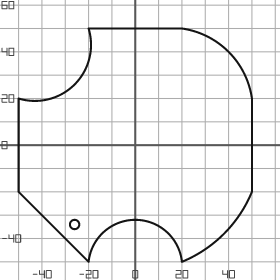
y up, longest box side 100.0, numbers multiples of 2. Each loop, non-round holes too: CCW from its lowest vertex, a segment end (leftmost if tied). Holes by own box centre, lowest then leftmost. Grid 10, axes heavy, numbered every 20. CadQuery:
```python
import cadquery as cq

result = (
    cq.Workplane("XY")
    .moveTo(-20.0, -50.0)
    .threePointArc((0.0, -32.0), (20.0, -50.0))
    .threePointArc((38.0, -38.0), (50.0, -20.0))
    .lineTo(50.0, 20.0)
    .threePointArc((40.0, 40.0), (20.0, 50.0))
    .lineTo(-20.0, 50.0)
    .threePointArc((-26.0, 26.0), (-50.0, 20.0))
    .lineTo(-50.0, -20.0)
    .close()
    .moveTo(-26.0, -34.0)
    .circle(2.0)
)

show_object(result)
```